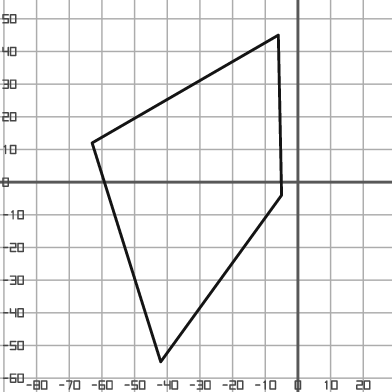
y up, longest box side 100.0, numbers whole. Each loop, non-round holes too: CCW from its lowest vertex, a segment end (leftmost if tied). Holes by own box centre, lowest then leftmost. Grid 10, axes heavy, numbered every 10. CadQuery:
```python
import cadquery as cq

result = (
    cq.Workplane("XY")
    .moveTo(-42.0, -55.0)
    .lineTo(-5.0, -4.0)
    .lineTo(-6.0, 45.0)
    .lineTo(-63.0, 12.0)
    .close()
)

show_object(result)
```